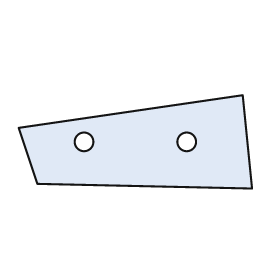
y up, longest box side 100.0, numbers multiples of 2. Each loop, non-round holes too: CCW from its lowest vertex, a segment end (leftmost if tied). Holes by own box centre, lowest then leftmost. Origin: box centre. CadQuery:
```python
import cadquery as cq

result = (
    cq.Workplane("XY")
    .moveTo(50.0, -20.0)
    .lineTo(46.0, 20.0)
    .lineTo(-50.0, 6.0)
    .lineTo(-42.0, -18.0)
    .close()
    .moveTo(-22.0, 0.0)
    .circle(4.0)
    .moveTo(22.0, 0.0)
    .circle(4.0)
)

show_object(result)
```